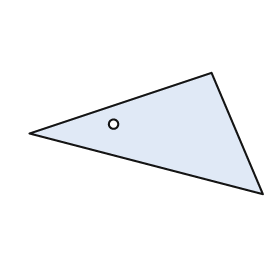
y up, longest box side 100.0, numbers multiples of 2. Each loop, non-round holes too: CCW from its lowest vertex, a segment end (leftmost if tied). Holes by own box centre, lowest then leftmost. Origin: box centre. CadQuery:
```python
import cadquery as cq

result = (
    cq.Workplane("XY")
    .moveTo(50.0, -26.0)
    .lineTo(28.0, 26.0)
    .lineTo(-50.0, 0.0)
    .close()
    .moveTo(-14.0, 4.0)
    .circle(2.0)
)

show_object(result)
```